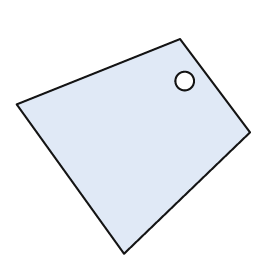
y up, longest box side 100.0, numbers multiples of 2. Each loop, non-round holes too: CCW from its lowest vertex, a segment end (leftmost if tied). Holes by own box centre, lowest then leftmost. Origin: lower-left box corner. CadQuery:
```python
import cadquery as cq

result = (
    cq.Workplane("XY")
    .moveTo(46.0, 0.0)
    .lineTo(100.0, 52.0)
    .lineTo(70.0, 92.0)
    .lineTo(0.0, 64.0)
    .close()
    .moveTo(72.0, 74.0)
    .circle(4.0)
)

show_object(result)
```